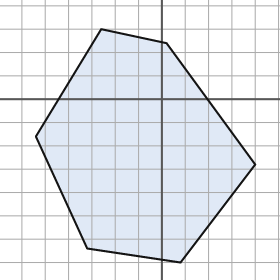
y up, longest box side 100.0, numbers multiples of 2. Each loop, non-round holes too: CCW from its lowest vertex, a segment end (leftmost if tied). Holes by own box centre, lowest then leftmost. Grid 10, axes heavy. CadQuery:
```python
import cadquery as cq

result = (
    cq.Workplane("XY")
    .moveTo(8.0, -70.0)
    .lineTo(40.0, -28.0)
    .lineTo(2.0, 24.0)
    .lineTo(-26.0, 30.0)
    .lineTo(-54.0, -16.0)
    .lineTo(-32.0, -64.0)
    .close()
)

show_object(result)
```